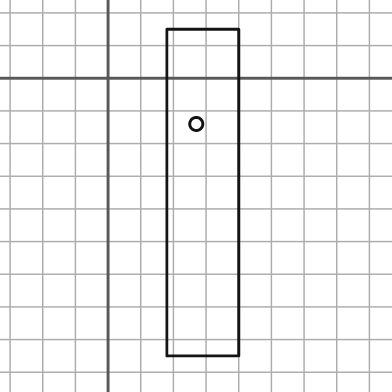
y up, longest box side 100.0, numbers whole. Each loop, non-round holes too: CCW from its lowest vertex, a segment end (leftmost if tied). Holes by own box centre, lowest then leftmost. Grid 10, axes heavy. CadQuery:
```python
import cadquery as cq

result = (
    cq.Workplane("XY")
    .moveTo(18.0, -85.0)
    .lineTo(40.0, -85.0)
    .lineTo(40.0, 15.0)
    .lineTo(18.0, 15.0)
    .close()
    .moveTo(27.0, -14.0)
    .circle(2.0)
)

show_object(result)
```